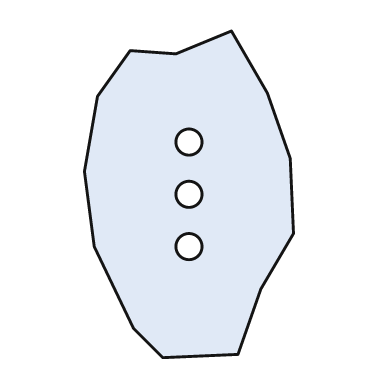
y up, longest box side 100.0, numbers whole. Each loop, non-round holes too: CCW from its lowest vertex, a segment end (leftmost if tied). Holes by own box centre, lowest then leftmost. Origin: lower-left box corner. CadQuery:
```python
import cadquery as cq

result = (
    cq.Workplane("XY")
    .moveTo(24.0, 0.0)
    .lineTo(47.0, 1.0)
    .lineTo(54.0, 21.0)
    .lineTo(64.0, 38.0)
    .lineTo(63.0, 61.0)
    .lineTo(56.0, 81.0)
    .lineTo(45.0, 100.0)
    .lineTo(28.0, 93.0)
    .lineTo(14.0, 94.0)
    .lineTo(4.0, 80.0)
    .lineTo(0.0, 57.0)
    .lineTo(3.0, 34.0)
    .lineTo(15.0, 9.0)
    .close()
    .moveTo(32.0, 34.0)
    .circle(4.0)
    .moveTo(32.0, 50.0)
    .circle(4.0)
    .moveTo(32.0, 66.0)
    .circle(4.0)
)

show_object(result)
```